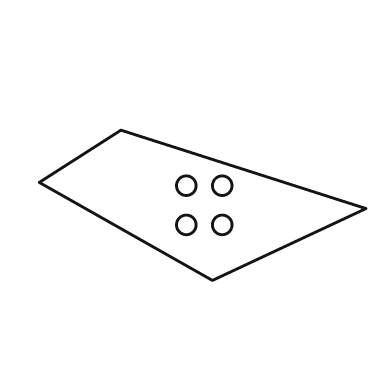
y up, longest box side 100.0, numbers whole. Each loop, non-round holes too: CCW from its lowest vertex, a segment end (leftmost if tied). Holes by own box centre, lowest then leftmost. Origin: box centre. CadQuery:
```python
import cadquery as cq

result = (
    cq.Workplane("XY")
    .moveTo(3.0, -23.0)
    .lineTo(50.0, -1.0)
    .lineTo(-25.0, 23.0)
    .lineTo(-50.0, 7.0)
    .close()
    .moveTo(-5.0, -6.0)
    .circle(3.0)
    .moveTo(6.0, -6.0)
    .circle(3.0)
    .moveTo(-5.0, 6.0)
    .circle(3.0)
    .moveTo(6.0, 6.0)
    .circle(3.0)
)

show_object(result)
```